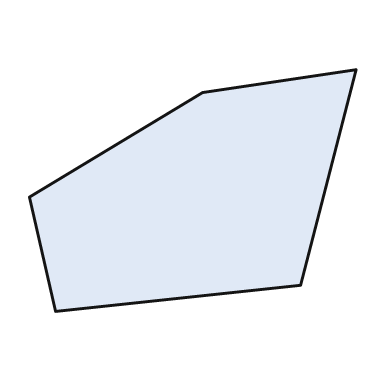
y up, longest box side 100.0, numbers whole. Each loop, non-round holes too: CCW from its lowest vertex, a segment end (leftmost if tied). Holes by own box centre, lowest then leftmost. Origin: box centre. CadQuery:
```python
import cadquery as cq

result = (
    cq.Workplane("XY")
    .moveTo(-42.0, -37.0)
    .lineTo(33.0, -29.0)
    .lineTo(50.0, 37.0)
    .lineTo(3.0, 30.0)
    .lineTo(-50.0, -2.0)
    .close()
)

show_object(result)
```